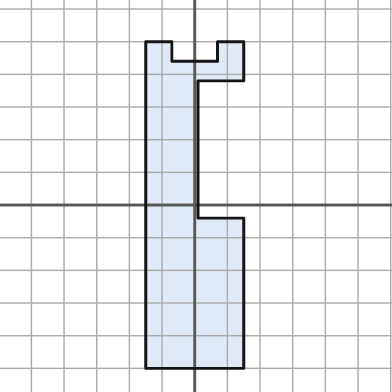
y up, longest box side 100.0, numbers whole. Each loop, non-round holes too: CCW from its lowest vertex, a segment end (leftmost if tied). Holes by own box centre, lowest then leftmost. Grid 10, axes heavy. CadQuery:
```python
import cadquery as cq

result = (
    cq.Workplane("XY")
    .moveTo(-15.0, -50.0)
    .lineTo(15.0, -50.0)
    .lineTo(15.0, -4.0)
    .lineTo(1.0, -4.0)
    .lineTo(1.0, 38.0)
    .lineTo(15.0, 38.0)
    .lineTo(15.0, 50.0)
    .lineTo(7.0, 50.0)
    .lineTo(7.0, 44.0)
    .lineTo(-7.0, 44.0)
    .lineTo(-7.0, 50.0)
    .lineTo(-15.0, 50.0)
    .close()
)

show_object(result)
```